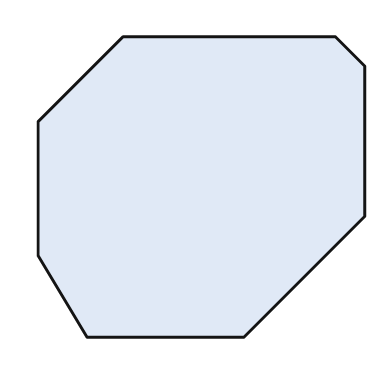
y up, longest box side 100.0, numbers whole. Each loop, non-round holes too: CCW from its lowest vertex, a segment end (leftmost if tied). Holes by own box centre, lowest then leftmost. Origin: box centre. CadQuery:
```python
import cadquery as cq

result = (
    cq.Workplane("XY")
    .moveTo(-35.0, -46.0)
    .lineTo(13.0, -46.0)
    .lineTo(50.0, -9.0)
    .lineTo(50.0, 37.0)
    .lineTo(41.0, 46.0)
    .lineTo(-24.0, 46.0)
    .lineTo(-50.0, 20.0)
    .lineTo(-50.0, -21.0)
    .close()
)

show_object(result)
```